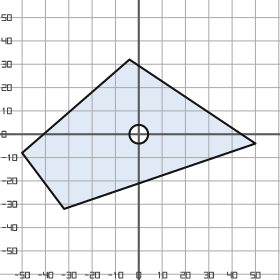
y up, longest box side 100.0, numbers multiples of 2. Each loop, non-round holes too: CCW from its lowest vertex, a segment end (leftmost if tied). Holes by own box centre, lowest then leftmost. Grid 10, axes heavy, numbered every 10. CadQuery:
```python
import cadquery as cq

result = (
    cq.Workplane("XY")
    .moveTo(-32.0, -32.0)
    .lineTo(50.0, -4.0)
    .lineTo(-4.0, 32.0)
    .lineTo(-50.0, -8.0)
    .close()
    .moveTo(0.0, 0.0)
    .circle(4.0)
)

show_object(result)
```